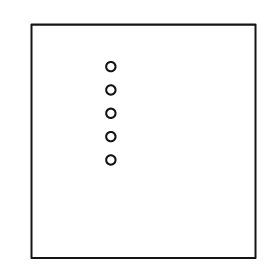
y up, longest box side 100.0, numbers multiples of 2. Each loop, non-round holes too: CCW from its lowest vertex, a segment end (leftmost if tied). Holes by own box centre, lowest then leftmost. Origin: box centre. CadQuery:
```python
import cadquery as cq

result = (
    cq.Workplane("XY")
    .moveTo(-48.0, -50.0)
    .lineTo(48.0, -50.0)
    .lineTo(48.0, 50.0)
    .lineTo(-48.0, 50.0)
    .close()
    .moveTo(-14.0, -8.0)
    .circle(2.0)
    .moveTo(-14.0, 2.0)
    .circle(2.0)
    .moveTo(-14.0, 12.0)
    .circle(2.0)
    .moveTo(-14.0, 22.0)
    .circle(2.0)
    .moveTo(-14.0, 32.0)
    .circle(2.0)
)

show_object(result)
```